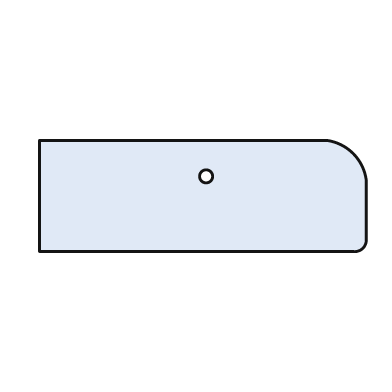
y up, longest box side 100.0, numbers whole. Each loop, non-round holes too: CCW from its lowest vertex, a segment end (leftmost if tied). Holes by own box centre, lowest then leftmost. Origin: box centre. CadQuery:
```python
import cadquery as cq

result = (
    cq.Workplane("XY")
    .moveTo(-50.0, -17.0)
    .lineTo(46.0, -17.0)
    .threePointArc((49.0, -16.0), (50.0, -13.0))
    .lineTo(50.0, 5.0)
    .threePointArc((46.0, 13.0), (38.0, 17.0))
    .lineTo(-50.0, 17.0)
    .close()
    .moveTo(1.0, 6.0)
    .circle(2.0)
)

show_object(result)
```